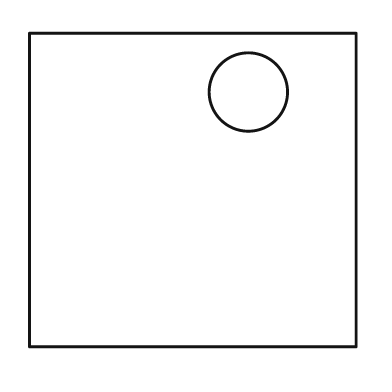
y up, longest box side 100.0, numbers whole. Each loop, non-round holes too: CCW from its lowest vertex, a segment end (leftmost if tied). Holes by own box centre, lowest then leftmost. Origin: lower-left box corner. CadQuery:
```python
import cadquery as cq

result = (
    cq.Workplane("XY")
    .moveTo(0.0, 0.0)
    .lineTo(100.0, 0.0)
    .lineTo(100.0, 96.0)
    .lineTo(0.0, 96.0)
    .close()
    .moveTo(67.0, 78.0)
    .circle(12.0)
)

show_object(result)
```